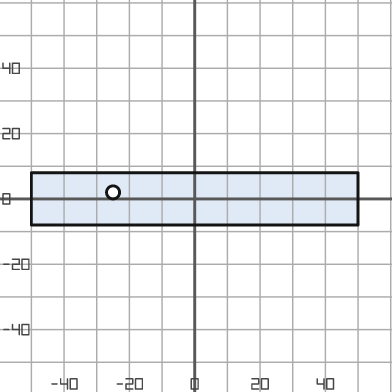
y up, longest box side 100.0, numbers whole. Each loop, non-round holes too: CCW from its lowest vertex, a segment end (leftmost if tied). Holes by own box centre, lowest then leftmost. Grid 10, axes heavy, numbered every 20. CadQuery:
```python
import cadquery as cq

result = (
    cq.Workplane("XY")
    .moveTo(-50.0, -8.0)
    .lineTo(50.0, -8.0)
    .lineTo(50.0, 8.0)
    .lineTo(-50.0, 8.0)
    .close()
    .moveTo(-25.0, 2.0)
    .circle(2.0)
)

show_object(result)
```